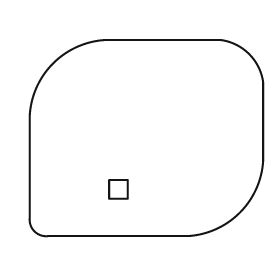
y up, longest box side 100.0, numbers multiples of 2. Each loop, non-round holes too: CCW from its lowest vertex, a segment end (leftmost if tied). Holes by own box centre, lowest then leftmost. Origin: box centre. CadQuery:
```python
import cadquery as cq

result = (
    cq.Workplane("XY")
    .moveTo(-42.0, -42.0)
    .lineTo(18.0, -42.0)
    .threePointArc((40.0, -32.0), (50.0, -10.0))
    .lineTo(50.0, 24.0)
    .threePointArc((44.0, 36.0), (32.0, 42.0))
    .lineTo(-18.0, 42.0)
    .threePointArc((-40.0, 32.0), (-50.0, 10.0))
    .lineTo(-50.0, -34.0)
    .threePointArc((-48.0, -40.0), (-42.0, -42.0))
    .close()
    .moveTo(-16.0, -26.0)
    .lineTo(-8.0, -26.0)
    .lineTo(-8.0, -18.0)
    .lineTo(-16.0, -18.0)
    .close()
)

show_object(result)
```